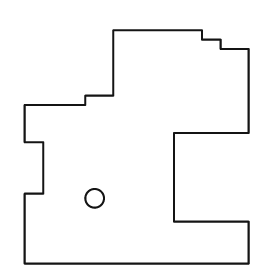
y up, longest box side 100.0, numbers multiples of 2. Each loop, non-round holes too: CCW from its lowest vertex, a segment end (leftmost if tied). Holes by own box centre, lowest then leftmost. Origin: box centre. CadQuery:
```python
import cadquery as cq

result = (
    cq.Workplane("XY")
    .moveTo(-48.0, -50.0)
    .lineTo(48.0, -50.0)
    .lineTo(48.0, -32.0)
    .lineTo(16.0, -32.0)
    .lineTo(16.0, 6.0)
    .lineTo(48.0, 6.0)
    .lineTo(48.0, 42.0)
    .lineTo(36.0, 42.0)
    .lineTo(36.0, 46.0)
    .lineTo(28.0, 46.0)
    .lineTo(28.0, 50.0)
    .lineTo(-10.0, 50.0)
    .lineTo(-10.0, 22.0)
    .lineTo(-22.0, 22.0)
    .lineTo(-22.0, 18.0)
    .lineTo(-48.0, 18.0)
    .lineTo(-48.0, 2.0)
    .lineTo(-40.0, 2.0)
    .lineTo(-40.0, -20.0)
    .lineTo(-48.0, -20.0)
    .close()
    .moveTo(-18.0, -22.0)
    .circle(4.0)
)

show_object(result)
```